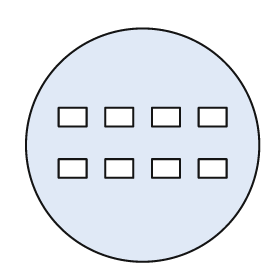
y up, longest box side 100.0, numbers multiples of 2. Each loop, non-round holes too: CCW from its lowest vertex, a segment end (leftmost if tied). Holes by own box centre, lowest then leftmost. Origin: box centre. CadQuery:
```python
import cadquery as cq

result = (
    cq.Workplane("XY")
    .moveTo(0.0, 0.0)
    .circle(50.0)
    .moveTo(-36.0, -14.0)
    .lineTo(-24.0, -14.0)
    .lineTo(-24.0, -6.0)
    .lineTo(-36.0, -6.0)
    .close()
    .moveTo(-16.0, -14.0)
    .lineTo(-4.0, -14.0)
    .lineTo(-4.0, -6.0)
    .lineTo(-16.0, -6.0)
    .close()
    .moveTo(4.0, -14.0)
    .lineTo(16.0, -14.0)
    .lineTo(16.0, -6.0)
    .lineTo(4.0, -6.0)
    .close()
    .moveTo(24.0, -14.0)
    .lineTo(36.0, -14.0)
    .lineTo(36.0, -6.0)
    .lineTo(24.0, -6.0)
    .close()
    .moveTo(-36.0, 8.0)
    .lineTo(-24.0, 8.0)
    .lineTo(-24.0, 16.0)
    .lineTo(-36.0, 16.0)
    .close()
    .moveTo(-16.0, 8.0)
    .lineTo(-4.0, 8.0)
    .lineTo(-4.0, 16.0)
    .lineTo(-16.0, 16.0)
    .close()
    .moveTo(4.0, 8.0)
    .lineTo(16.0, 8.0)
    .lineTo(16.0, 16.0)
    .lineTo(4.0, 16.0)
    .close()
    .moveTo(24.0, 8.0)
    .lineTo(36.0, 8.0)
    .lineTo(36.0, 16.0)
    .lineTo(24.0, 16.0)
    .close()
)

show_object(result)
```